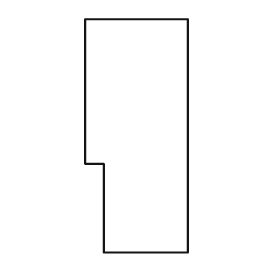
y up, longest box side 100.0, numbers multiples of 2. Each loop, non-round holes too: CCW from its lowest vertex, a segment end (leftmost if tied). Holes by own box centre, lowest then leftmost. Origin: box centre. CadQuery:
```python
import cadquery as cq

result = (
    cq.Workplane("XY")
    .moveTo(-14.0, -50.0)
    .lineTo(22.0, -50.0)
    .lineTo(22.0, 50.0)
    .lineTo(-22.0, 50.0)
    .lineTo(-22.0, -12.0)
    .lineTo(-14.0, -12.0)
    .close()
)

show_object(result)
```